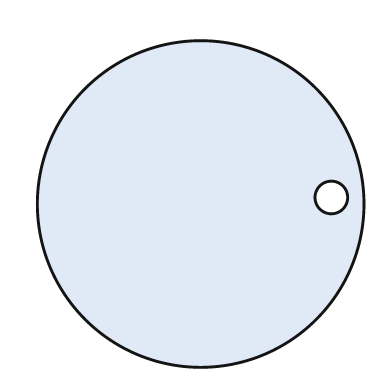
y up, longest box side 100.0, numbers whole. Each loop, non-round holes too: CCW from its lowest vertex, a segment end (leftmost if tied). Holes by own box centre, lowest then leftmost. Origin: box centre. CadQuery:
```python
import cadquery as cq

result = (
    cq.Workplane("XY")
    .moveTo(0.0, 0.0)
    .circle(50.0)
    .moveTo(40.0, 2.0)
    .circle(5.0)
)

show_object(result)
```